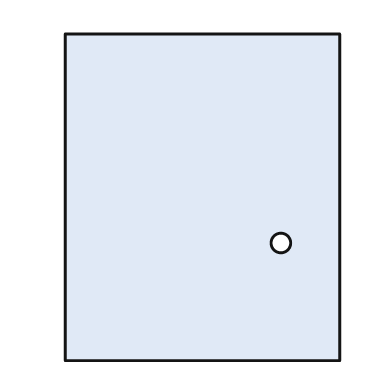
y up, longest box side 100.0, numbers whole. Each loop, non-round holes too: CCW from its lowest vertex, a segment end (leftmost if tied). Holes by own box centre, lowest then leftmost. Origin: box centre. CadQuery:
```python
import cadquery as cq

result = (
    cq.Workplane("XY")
    .moveTo(-42.0, -50.0)
    .lineTo(42.0, -50.0)
    .lineTo(42.0, 50.0)
    .lineTo(-42.0, 50.0)
    .close()
    .moveTo(24.0, -14.0)
    .circle(3.0)
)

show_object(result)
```